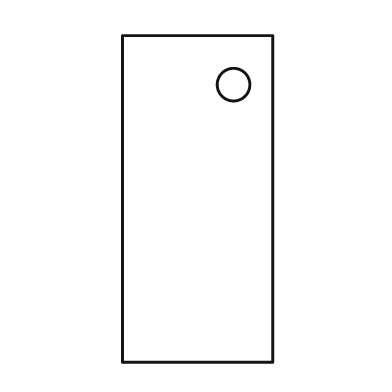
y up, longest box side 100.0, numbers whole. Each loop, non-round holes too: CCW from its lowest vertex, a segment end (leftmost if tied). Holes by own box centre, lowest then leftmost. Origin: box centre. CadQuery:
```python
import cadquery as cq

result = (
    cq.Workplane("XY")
    .moveTo(-23.0, -50.0)
    .lineTo(23.0, -50.0)
    .lineTo(23.0, 50.0)
    .lineTo(-23.0, 50.0)
    .close()
    .moveTo(11.0, 35.0)
    .circle(5.0)
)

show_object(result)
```